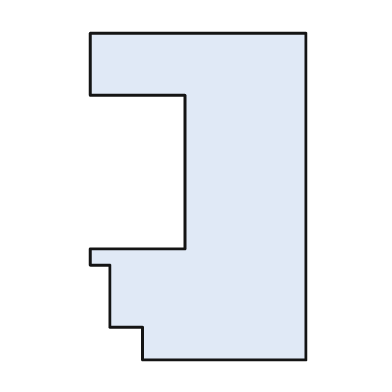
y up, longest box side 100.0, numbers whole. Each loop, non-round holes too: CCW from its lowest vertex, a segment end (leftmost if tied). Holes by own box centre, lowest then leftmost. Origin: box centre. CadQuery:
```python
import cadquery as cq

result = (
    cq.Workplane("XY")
    .moveTo(-17.0, -50.0)
    .lineTo(33.0, -50.0)
    .lineTo(33.0, 50.0)
    .lineTo(-33.0, 50.0)
    .lineTo(-33.0, 31.0)
    .lineTo(-4.0, 31.0)
    .lineTo(-4.0, -16.0)
    .lineTo(-33.0, -16.0)
    .lineTo(-33.0, -21.0)
    .lineTo(-27.0, -21.0)
    .lineTo(-27.0, -40.0)
    .lineTo(-17.0, -40.0)
    .close()
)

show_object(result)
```